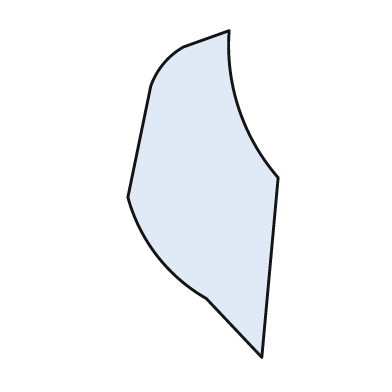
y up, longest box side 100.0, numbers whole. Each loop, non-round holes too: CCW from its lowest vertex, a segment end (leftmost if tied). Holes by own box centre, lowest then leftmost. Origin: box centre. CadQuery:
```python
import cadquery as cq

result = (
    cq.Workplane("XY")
    .moveTo(18.0, -50.0)
    .lineTo(23.0, 5.0)
    .threePointArc((11.0, 26.0), (8.0, 50.0))
    .lineTo(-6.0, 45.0)
    .threePointArc((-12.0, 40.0), (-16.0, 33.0))
    .lineTo(-23.0, -1.0)
    .threePointArc((-14.0, -19.0), (1.0, -32.0))
    .close()
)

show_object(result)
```